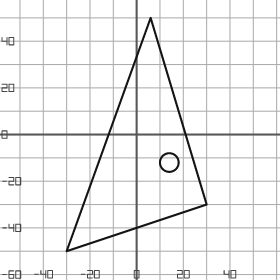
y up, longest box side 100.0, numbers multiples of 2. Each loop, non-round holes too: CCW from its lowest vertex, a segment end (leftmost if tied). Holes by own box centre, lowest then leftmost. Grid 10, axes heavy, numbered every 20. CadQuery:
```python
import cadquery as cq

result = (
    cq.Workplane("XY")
    .moveTo(-30.0, -50.0)
    .lineTo(30.0, -30.0)
    .lineTo(6.0, 50.0)
    .close()
    .moveTo(14.0, -12.0)
    .circle(4.0)
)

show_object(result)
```